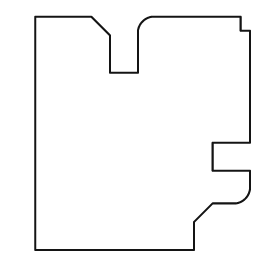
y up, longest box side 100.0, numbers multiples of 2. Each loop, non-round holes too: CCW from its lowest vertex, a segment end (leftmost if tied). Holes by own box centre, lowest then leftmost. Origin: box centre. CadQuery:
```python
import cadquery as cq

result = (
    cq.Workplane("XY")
    .moveTo(-46.0, -50.0)
    .lineTo(22.0, -50.0)
    .lineTo(22.0, -38.0)
    .lineTo(30.0, -30.0)
    .lineTo(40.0, -30.0)
    .threePointArc((44.0, -28.0), (46.0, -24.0))
    .lineTo(46.0, -16.0)
    .lineTo(30.0, -16.0)
    .lineTo(30.0, -4.0)
    .lineTo(46.0, -4.0)
    .lineTo(46.0, 44.0)
    .lineTo(42.0, 44.0)
    .lineTo(42.0, 50.0)
    .lineTo(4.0, 50.0)
    .threePointArc((0.0, 48.0), (-2.0, 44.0))
    .lineTo(-2.0, 26.0)
    .lineTo(-14.0, 26.0)
    .lineTo(-14.0, 42.0)
    .lineTo(-22.0, 50.0)
    .lineTo(-46.0, 50.0)
    .close()
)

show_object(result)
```